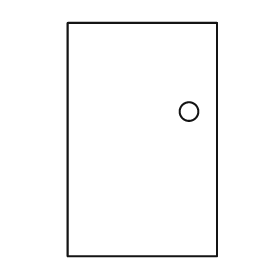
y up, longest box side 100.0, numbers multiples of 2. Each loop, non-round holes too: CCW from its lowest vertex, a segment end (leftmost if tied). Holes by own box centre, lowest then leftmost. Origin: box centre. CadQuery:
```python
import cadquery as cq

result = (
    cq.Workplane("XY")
    .moveTo(-32.0, -50.0)
    .lineTo(32.0, -50.0)
    .lineTo(32.0, 50.0)
    .lineTo(-32.0, 50.0)
    .close()
    .moveTo(20.0, 12.0)
    .circle(4.0)
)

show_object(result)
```